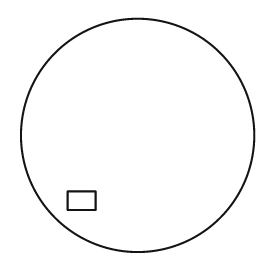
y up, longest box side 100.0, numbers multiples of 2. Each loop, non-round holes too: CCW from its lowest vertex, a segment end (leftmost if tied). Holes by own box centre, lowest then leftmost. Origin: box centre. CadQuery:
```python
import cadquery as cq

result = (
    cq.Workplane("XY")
    .moveTo(0.0, 0.0)
    .circle(50.0)
    .moveTo(-30.0, -32.0)
    .lineTo(-18.0, -32.0)
    .lineTo(-18.0, -24.0)
    .lineTo(-30.0, -24.0)
    .close()
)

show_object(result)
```